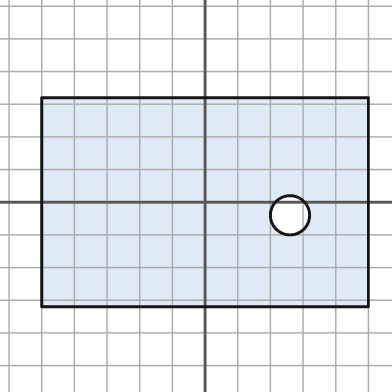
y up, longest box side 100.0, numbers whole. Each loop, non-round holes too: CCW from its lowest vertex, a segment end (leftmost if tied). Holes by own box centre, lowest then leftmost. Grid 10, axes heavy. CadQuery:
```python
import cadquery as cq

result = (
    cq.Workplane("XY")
    .moveTo(-50.0, -32.0)
    .lineTo(50.0, -32.0)
    .lineTo(50.0, 32.0)
    .lineTo(-50.0, 32.0)
    .close()
    .moveTo(26.0, -4.0)
    .circle(6.0)
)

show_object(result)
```